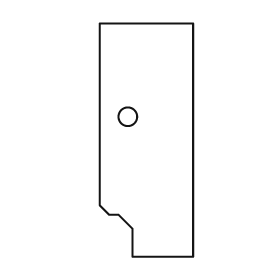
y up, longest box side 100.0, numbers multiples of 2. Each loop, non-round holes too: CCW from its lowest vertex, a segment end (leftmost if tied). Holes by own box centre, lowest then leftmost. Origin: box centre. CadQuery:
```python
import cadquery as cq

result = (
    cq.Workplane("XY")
    .moveTo(-6.0, -50.0)
    .lineTo(20.0, -50.0)
    .lineTo(20.0, 50.0)
    .lineTo(-20.0, 50.0)
    .lineTo(-20.0, -28.0)
    .lineTo(-16.0, -32.0)
    .lineTo(-12.0, -32.0)
    .lineTo(-6.0, -38.0)
    .close()
    .moveTo(-8.0, 10.0)
    .circle(4.0)
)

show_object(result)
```